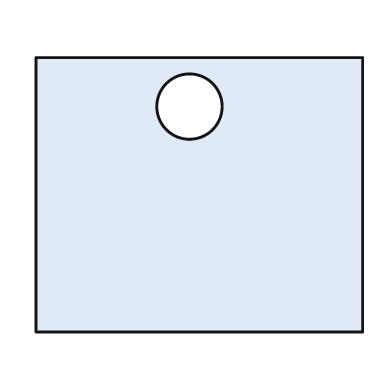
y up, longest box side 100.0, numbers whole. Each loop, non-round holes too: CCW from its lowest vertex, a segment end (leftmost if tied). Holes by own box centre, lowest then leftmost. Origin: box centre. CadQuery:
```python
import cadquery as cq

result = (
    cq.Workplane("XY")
    .moveTo(-50.0, -42.0)
    .lineTo(50.0, -42.0)
    .lineTo(50.0, 42.0)
    .lineTo(-50.0, 42.0)
    .close()
    .moveTo(-3.0, 27.0)
    .circle(10.0)
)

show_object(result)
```